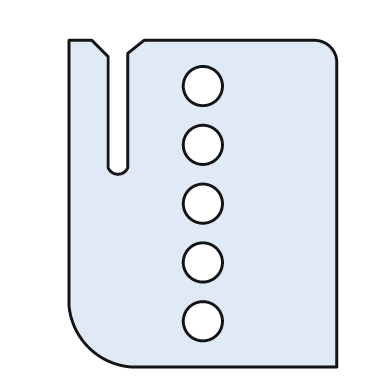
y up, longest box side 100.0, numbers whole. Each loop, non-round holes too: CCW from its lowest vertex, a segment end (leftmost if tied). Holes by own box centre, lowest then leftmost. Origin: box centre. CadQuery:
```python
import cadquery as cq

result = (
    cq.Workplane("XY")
    .moveTo(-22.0, -50.0)
    .lineTo(41.0, -50.0)
    .lineTo(41.0, 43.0)
    .threePointArc((39.0, 48.0), (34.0, 50.0))
    .lineTo(-18.0, 50.0)
    .lineTo(-23.0, 46.0)
    .lineTo(-23.0, 11.0)
    .threePointArc((-26.0, 9.0), (-29.0, 11.0))
    .lineTo(-29.0, 45.0)
    .lineTo(-34.0, 50.0)
    .lineTo(-41.0, 50.0)
    .lineTo(-41.0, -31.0)
    .threePointArc((-35.0, -44.0), (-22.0, -50.0))
    .close()
    .moveTo(0.0, -36.0)
    .circle(6.0)
    .moveTo(0.0, -18.0)
    .circle(6.0)
    .moveTo(0.0, 0.0)
    .circle(6.0)
    .moveTo(0.0, 18.0)
    .circle(6.0)
    .moveTo(0.0, 36.0)
    .circle(6.0)
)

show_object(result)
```